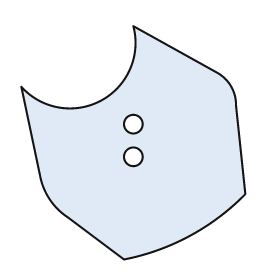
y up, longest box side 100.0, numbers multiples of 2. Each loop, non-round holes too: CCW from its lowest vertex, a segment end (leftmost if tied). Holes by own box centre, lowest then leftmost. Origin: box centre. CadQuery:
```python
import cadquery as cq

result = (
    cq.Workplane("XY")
    .moveTo(-4.0, -50.0)
    .threePointArc((24.0, -40.0), (48.0, -22.0))
    .lineTo(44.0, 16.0)
    .threePointArc((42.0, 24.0), (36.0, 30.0))
    .lineTo(0.0, 50.0)
    .threePointArc((-14.0, 18.0), (-48.0, 24.0))
    .lineTo(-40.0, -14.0)
    .threePointArc((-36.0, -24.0), (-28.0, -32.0))
    .close()
    .moveTo(0.0, -6.0)
    .circle(4.0)
    .moveTo(0.0, 8.0)
    .circle(4.0)
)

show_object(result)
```